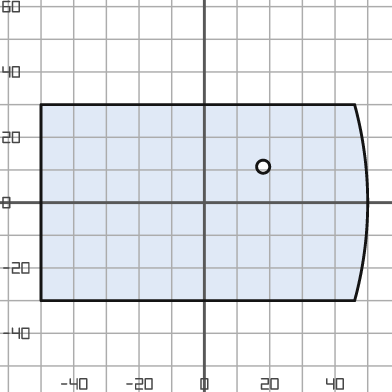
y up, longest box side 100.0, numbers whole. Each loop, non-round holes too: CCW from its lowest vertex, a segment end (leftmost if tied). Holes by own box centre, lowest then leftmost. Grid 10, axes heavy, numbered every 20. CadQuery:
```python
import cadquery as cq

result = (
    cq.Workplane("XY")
    .moveTo(-50.0, -30.0)
    .lineTo(46.0, -30.0)
    .threePointArc((50.0, 0.0), (46.0, 30.0))
    .lineTo(-50.0, 30.0)
    .close()
    .moveTo(18.0, 11.0)
    .circle(2.0)
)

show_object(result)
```